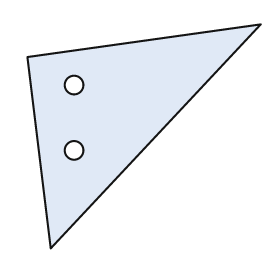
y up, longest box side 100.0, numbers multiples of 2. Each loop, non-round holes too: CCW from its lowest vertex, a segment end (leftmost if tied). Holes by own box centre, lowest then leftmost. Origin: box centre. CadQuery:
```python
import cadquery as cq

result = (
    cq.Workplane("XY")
    .moveTo(-40.0, -48.0)
    .lineTo(50.0, 48.0)
    .lineTo(-50.0, 34.0)
    .close()
    .moveTo(-30.0, -6.0)
    .circle(4.0)
    .moveTo(-30.0, 22.0)
    .circle(4.0)
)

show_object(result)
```